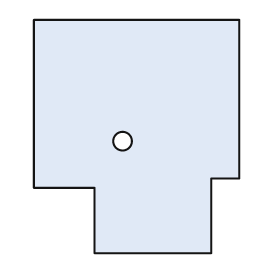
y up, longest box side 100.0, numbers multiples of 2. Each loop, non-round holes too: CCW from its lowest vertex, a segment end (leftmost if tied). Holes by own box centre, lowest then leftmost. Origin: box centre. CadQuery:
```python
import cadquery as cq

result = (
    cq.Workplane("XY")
    .moveTo(-18.0, -50.0)
    .lineTo(32.0, -50.0)
    .lineTo(32.0, -18.0)
    .lineTo(44.0, -18.0)
    .lineTo(44.0, 50.0)
    .lineTo(-44.0, 50.0)
    .lineTo(-44.0, -22.0)
    .lineTo(-18.0, -22.0)
    .close()
    .moveTo(-6.0, -2.0)
    .circle(4.0)
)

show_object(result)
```